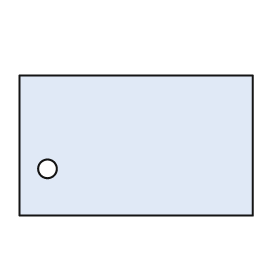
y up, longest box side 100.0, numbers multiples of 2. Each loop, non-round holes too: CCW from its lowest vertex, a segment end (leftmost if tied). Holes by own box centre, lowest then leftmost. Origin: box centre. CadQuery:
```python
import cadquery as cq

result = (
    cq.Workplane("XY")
    .moveTo(-50.0, -30.0)
    .lineTo(50.0, -30.0)
    .lineTo(50.0, 30.0)
    .lineTo(-50.0, 30.0)
    .close()
    .moveTo(-38.0, -10.0)
    .circle(4.0)
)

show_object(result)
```